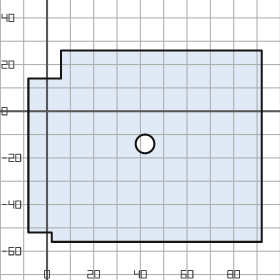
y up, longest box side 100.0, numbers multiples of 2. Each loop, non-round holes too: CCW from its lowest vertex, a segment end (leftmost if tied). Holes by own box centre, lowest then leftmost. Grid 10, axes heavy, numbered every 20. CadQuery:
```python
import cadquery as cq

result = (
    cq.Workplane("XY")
    .moveTo(2.0, -56.0)
    .lineTo(92.0, -56.0)
    .lineTo(92.0, 26.0)
    .lineTo(6.0, 26.0)
    .lineTo(6.0, 14.0)
    .lineTo(-8.0, 14.0)
    .lineTo(-8.0, -52.0)
    .lineTo(2.0, -52.0)
    .close()
    .moveTo(42.0, -14.0)
    .circle(4.0)
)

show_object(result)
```